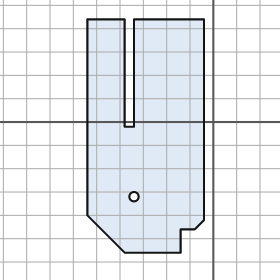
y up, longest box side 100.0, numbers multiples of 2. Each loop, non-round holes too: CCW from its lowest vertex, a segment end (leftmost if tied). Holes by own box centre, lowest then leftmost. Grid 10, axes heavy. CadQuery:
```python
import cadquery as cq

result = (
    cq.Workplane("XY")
    .moveTo(-38.0, -56.0)
    .lineTo(-14.0, -56.0)
    .lineTo(-14.0, -46.0)
    .lineTo(-8.0, -46.0)
    .lineTo(-4.0, -42.0)
    .lineTo(-4.0, 44.0)
    .lineTo(-34.0, 44.0)
    .lineTo(-34.0, -2.0)
    .lineTo(-38.0, -2.0)
    .lineTo(-38.0, 44.0)
    .lineTo(-54.0, 44.0)
    .lineTo(-54.0, -40.0)
    .close()
    .moveTo(-34.0, -32.0)
    .circle(2.0)
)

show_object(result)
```